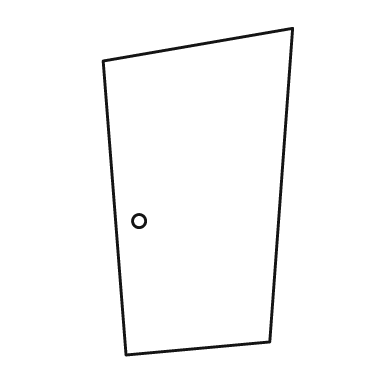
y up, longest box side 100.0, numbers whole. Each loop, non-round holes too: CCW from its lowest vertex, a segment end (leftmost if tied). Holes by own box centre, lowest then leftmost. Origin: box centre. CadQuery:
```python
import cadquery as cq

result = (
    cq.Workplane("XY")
    .moveTo(-22.0, -50.0)
    .lineTo(22.0, -46.0)
    .lineTo(29.0, 50.0)
    .lineTo(-29.0, 40.0)
    .close()
    .moveTo(-18.0, -9.0)
    .circle(2.0)
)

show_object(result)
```